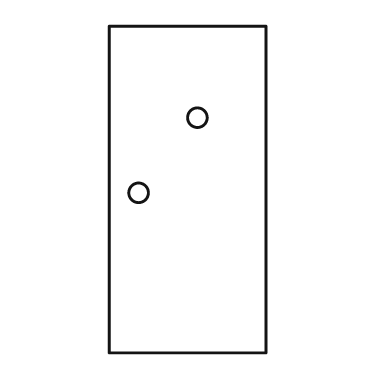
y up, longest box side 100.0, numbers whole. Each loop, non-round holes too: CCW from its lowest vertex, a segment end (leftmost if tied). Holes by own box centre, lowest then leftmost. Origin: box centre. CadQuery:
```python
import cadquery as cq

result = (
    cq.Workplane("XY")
    .moveTo(-24.0, -50.0)
    .lineTo(24.0, -50.0)
    .lineTo(24.0, 50.0)
    .lineTo(-24.0, 50.0)
    .close()
    .moveTo(-15.0, -1.0)
    .circle(3.0)
    .moveTo(3.0, 22.0)
    .circle(3.0)
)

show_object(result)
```